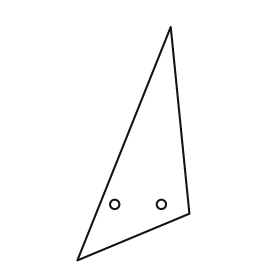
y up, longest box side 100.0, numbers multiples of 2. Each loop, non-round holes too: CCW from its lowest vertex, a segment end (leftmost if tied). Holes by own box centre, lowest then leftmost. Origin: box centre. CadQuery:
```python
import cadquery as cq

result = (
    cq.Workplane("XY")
    .moveTo(-24.0, -50.0)
    .lineTo(24.0, -30.0)
    .lineTo(16.0, 50.0)
    .close()
    .moveTo(-8.0, -26.0)
    .circle(2.0)
    .moveTo(12.0, -26.0)
    .circle(2.0)
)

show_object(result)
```